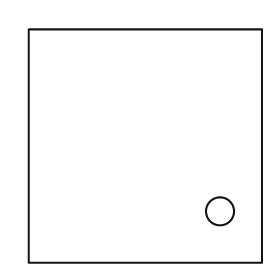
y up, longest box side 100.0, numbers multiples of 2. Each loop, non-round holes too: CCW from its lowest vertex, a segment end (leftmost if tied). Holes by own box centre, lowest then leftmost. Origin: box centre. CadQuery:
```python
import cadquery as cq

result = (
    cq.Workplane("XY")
    .moveTo(-50.0, -50.0)
    .lineTo(50.0, -50.0)
    .lineTo(50.0, 50.0)
    .lineTo(-50.0, 50.0)
    .close()
    .moveTo(32.0, -28.0)
    .circle(6.0)
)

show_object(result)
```